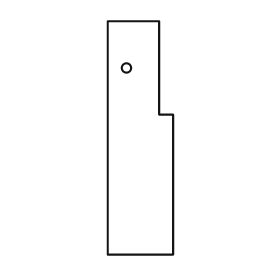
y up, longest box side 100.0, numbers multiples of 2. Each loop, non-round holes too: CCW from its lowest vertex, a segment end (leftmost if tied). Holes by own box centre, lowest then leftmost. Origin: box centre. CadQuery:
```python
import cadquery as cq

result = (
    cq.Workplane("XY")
    .moveTo(-14.0, -50.0)
    .lineTo(14.0, -50.0)
    .lineTo(14.0, 10.0)
    .lineTo(8.0, 10.0)
    .lineTo(8.0, 50.0)
    .lineTo(-14.0, 50.0)
    .close()
    .moveTo(-6.0, 30.0)
    .circle(2.0)
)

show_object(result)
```